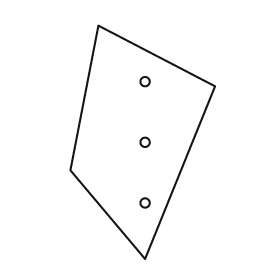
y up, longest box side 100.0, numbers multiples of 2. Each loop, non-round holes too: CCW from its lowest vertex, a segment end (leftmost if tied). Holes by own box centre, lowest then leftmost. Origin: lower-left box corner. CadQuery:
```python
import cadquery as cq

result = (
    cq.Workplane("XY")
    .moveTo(32.0, 0.0)
    .lineTo(62.0, 74.0)
    .lineTo(12.0, 100.0)
    .lineTo(0.0, 38.0)
    .close()
    .moveTo(32.0, 24.0)
    .circle(2.0)
    .moveTo(32.0, 50.0)
    .circle(2.0)
    .moveTo(32.0, 76.0)
    .circle(2.0)
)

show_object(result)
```